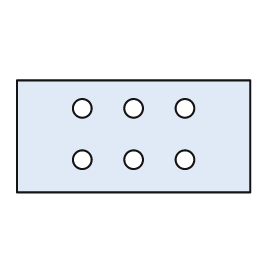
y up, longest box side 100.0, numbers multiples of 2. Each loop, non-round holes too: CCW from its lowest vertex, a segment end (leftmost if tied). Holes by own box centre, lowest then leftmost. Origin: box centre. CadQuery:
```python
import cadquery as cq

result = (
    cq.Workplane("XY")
    .moveTo(-50.0, -24.0)
    .lineTo(50.0, -24.0)
    .lineTo(50.0, 24.0)
    .lineTo(-50.0, 24.0)
    .close()
    .moveTo(-22.0, -10.0)
    .circle(4.0)
    .moveTo(0.0, -10.0)
    .circle(4.0)
    .moveTo(22.0, -10.0)
    .circle(4.0)
    .moveTo(-22.0, 12.0)
    .circle(4.0)
    .moveTo(0.0, 12.0)
    .circle(4.0)
    .moveTo(22.0, 12.0)
    .circle(4.0)
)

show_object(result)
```